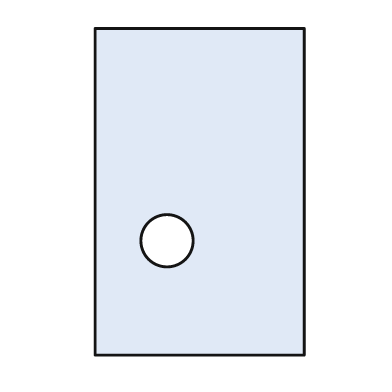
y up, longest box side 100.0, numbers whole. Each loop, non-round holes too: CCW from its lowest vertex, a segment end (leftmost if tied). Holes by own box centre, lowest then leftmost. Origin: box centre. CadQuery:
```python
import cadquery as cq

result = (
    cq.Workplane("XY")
    .moveTo(-32.0, -50.0)
    .lineTo(32.0, -50.0)
    .lineTo(32.0, 50.0)
    .lineTo(-32.0, 50.0)
    .close()
    .moveTo(-10.0, -15.0)
    .circle(8.0)
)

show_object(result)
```